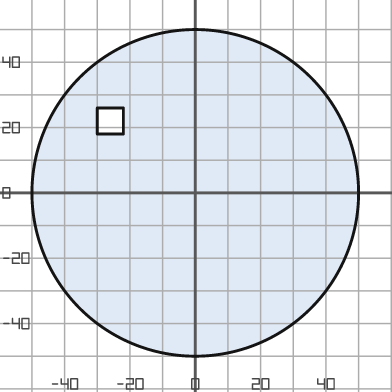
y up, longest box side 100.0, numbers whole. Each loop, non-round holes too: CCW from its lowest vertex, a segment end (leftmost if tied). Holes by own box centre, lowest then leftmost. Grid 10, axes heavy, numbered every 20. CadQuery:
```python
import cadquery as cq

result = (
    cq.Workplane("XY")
    .moveTo(0.0, 0.0)
    .circle(50.0)
    .moveTo(-30.0, 18.0)
    .lineTo(-22.0, 18.0)
    .lineTo(-22.0, 26.0)
    .lineTo(-30.0, 26.0)
    .close()
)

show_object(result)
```